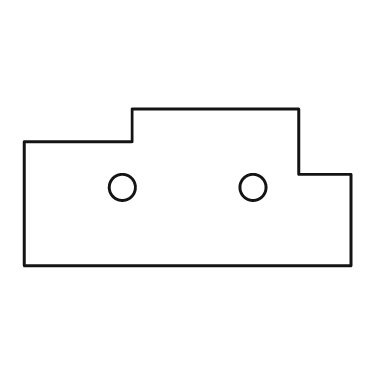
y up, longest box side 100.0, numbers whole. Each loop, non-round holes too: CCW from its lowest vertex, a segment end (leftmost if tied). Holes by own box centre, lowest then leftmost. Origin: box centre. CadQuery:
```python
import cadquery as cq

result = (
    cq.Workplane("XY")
    .moveTo(-50.0, -24.0)
    .lineTo(50.0, -24.0)
    .lineTo(50.0, 4.0)
    .lineTo(34.0, 4.0)
    .lineTo(34.0, 24.0)
    .lineTo(-17.0, 24.0)
    .lineTo(-17.0, 14.0)
    .lineTo(-50.0, 14.0)
    .close()
    .moveTo(-20.0, 0.0)
    .circle(4.0)
    .moveTo(20.0, 0.0)
    .circle(4.0)
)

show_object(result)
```